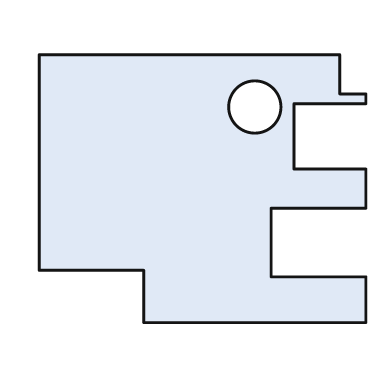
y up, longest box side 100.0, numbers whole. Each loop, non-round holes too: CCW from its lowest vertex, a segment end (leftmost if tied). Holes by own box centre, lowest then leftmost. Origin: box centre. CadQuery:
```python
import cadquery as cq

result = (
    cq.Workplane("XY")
    .moveTo(-18.0, -41.0)
    .lineTo(50.0, -41.0)
    .lineTo(50.0, -27.0)
    .lineTo(21.0, -27.0)
    .lineTo(21.0, -6.0)
    .lineTo(50.0, -6.0)
    .lineTo(50.0, 6.0)
    .lineTo(28.0, 6.0)
    .lineTo(28.0, 26.0)
    .lineTo(50.0, 26.0)
    .lineTo(50.0, 29.0)
    .lineTo(42.0, 29.0)
    .lineTo(42.0, 41.0)
    .lineTo(-50.0, 41.0)
    .lineTo(-50.0, -25.0)
    .lineTo(-18.0, -25.0)
    .close()
    .moveTo(16.0, 25.0)
    .circle(8.0)
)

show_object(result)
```